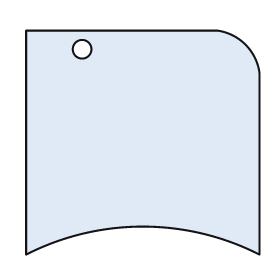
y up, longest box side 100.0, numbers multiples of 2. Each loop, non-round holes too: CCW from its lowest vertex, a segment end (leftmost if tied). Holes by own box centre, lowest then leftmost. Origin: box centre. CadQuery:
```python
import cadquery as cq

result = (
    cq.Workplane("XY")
    .moveTo(-50.0, -48.0)
    .threePointArc((0.0, -36.0), (50.0, -48.0))
    .lineTo(50.0, 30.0)
    .threePointArc((44.0, 42.0), (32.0, 48.0))
    .lineTo(-50.0, 48.0)
    .close()
    .moveTo(-26.0, 40.0)
    .circle(4.0)
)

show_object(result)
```